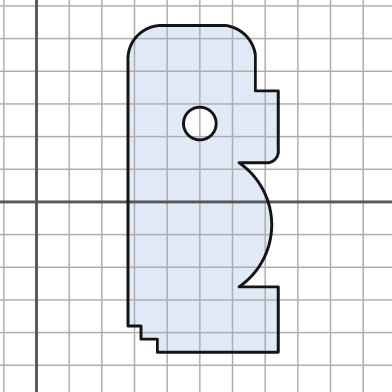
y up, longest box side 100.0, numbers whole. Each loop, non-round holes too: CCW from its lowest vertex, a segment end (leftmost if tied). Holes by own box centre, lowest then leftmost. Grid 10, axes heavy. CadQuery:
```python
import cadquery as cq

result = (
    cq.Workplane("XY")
    .moveTo(37.0, -46.0)
    .lineTo(74.0, -46.0)
    .lineTo(74.0, -26.0)
    .lineTo(62.0, -26.0)
    .threePointArc((72.0, -7.0), (62.0, 12.0))
    .lineTo(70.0, 12.0)
    .threePointArc((73.0, 13.0), (74.0, 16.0))
    .lineTo(74.0, 34.0)
    .lineTo(67.0, 34.0)
    .lineTo(67.0, 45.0)
    .threePointArc((64.0, 51.0), (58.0, 54.0))
    .lineTo(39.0, 54.0)
    .threePointArc((31.0, 51.0), (28.0, 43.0))
    .lineTo(28.0, -38.0)
    .lineTo(32.0, -38.0)
    .lineTo(32.0, -42.0)
    .lineTo(37.0, -42.0)
    .close()
    .moveTo(50.0, 24.0)
    .circle(5.0)
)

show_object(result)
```